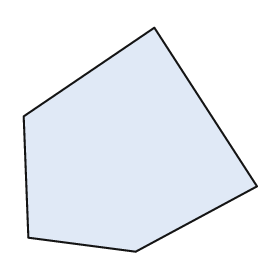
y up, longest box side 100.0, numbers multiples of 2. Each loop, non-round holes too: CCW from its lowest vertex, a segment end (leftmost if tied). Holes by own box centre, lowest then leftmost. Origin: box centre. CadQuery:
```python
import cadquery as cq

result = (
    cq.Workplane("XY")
    .moveTo(-2.0, -48.0)
    .lineTo(50.0, -20.0)
    .lineTo(6.0, 48.0)
    .lineTo(-50.0, 10.0)
    .lineTo(-48.0, -42.0)
    .close()
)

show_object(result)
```